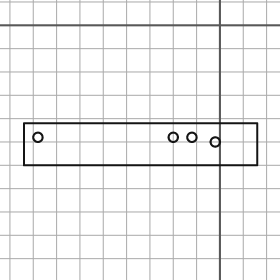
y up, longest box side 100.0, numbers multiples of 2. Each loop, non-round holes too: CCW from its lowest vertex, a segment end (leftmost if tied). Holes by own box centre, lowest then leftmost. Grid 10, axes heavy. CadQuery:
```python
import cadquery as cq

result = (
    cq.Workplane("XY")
    .moveTo(-84.0, -60.0)
    .lineTo(16.0, -60.0)
    .lineTo(16.0, -42.0)
    .lineTo(-84.0, -42.0)
    .close()
    .moveTo(-2.0, -50.0)
    .circle(2.0)
    .moveTo(-78.0, -48.0)
    .circle(2.0)
    .moveTo(-20.0, -48.0)
    .circle(2.0)
    .moveTo(-12.0, -48.0)
    .circle(2.0)
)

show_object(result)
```